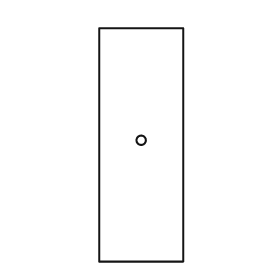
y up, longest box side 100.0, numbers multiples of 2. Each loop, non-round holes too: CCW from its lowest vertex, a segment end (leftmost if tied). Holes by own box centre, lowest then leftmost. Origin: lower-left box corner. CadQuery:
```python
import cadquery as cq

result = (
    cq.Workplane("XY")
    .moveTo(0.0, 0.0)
    .lineTo(36.0, 0.0)
    .lineTo(36.0, 100.0)
    .lineTo(0.0, 100.0)
    .close()
    .moveTo(18.0, 52.0)
    .circle(2.0)
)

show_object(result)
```